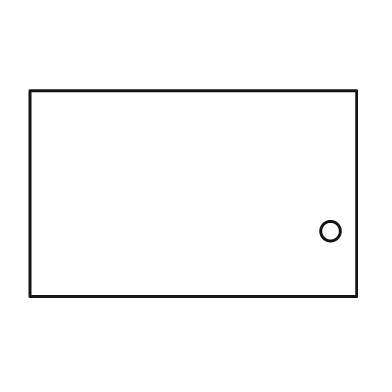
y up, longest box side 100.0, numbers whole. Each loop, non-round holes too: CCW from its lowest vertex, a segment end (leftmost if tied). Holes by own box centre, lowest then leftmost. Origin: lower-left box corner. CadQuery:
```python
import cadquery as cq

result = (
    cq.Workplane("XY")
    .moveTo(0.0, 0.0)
    .lineTo(100.0, 0.0)
    .lineTo(100.0, 63.0)
    .lineTo(0.0, 63.0)
    .close()
    .moveTo(92.0, 20.0)
    .circle(3.0)
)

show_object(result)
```